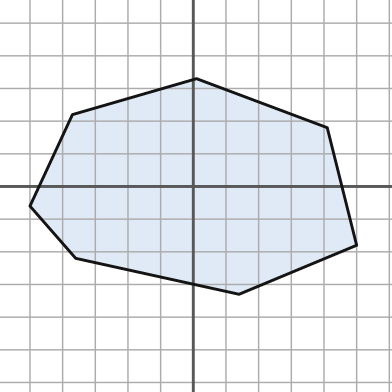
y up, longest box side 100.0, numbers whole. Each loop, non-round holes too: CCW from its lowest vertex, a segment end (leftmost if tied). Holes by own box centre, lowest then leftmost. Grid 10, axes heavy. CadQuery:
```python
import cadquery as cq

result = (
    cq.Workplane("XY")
    .moveTo(14.0, -33.0)
    .lineTo(50.0, -18.0)
    .lineTo(41.0, 18.0)
    .lineTo(1.0, 33.0)
    .lineTo(-37.0, 22.0)
    .lineTo(-50.0, -6.0)
    .lineTo(-36.0, -22.0)
    .close()
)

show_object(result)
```